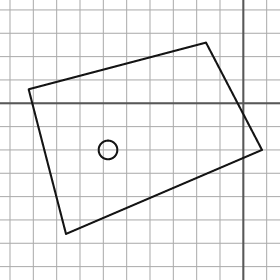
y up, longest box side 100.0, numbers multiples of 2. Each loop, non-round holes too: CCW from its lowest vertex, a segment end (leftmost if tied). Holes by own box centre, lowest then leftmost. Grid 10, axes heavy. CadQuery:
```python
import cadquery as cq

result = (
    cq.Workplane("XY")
    .moveTo(-76.0, -56.0)
    .lineTo(8.0, -20.0)
    .lineTo(-16.0, 26.0)
    .lineTo(-92.0, 6.0)
    .close()
    .moveTo(-58.0, -20.0)
    .circle(4.0)
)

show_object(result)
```